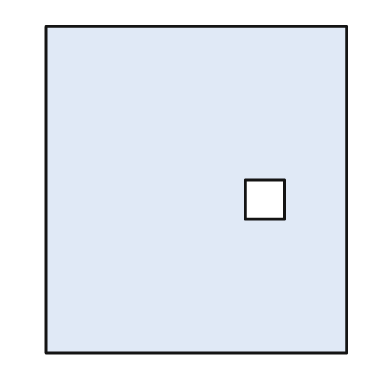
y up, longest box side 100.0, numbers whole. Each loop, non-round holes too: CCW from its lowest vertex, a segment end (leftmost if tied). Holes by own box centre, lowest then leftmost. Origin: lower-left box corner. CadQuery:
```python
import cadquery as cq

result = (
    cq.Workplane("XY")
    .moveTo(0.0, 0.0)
    .lineTo(92.0, 0.0)
    .lineTo(92.0, 100.0)
    .lineTo(0.0, 100.0)
    .close()
    .moveTo(61.0, 41.0)
    .lineTo(73.0, 41.0)
    .lineTo(73.0, 53.0)
    .lineTo(61.0, 53.0)
    .close()
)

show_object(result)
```